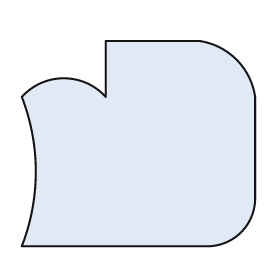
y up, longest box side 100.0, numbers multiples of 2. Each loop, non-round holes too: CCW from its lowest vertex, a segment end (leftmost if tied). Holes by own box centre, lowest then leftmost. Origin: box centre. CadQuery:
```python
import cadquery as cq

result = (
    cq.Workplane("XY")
    .moveTo(-50.0, -44.0)
    .lineTo(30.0, -44.0)
    .threePointArc((44.0, -38.0), (50.0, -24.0))
    .lineTo(50.0, 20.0)
    .threePointArc((42.0, 36.0), (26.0, 44.0))
    .lineTo(-14.0, 44.0)
    .lineTo(-14.0, 20.0)
    .threePointArc((-32.0, 28.0), (-50.0, 20.0))
    .threePointArc((-44.0, -12.0), (-50.0, -44.0))
    .close()
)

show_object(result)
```